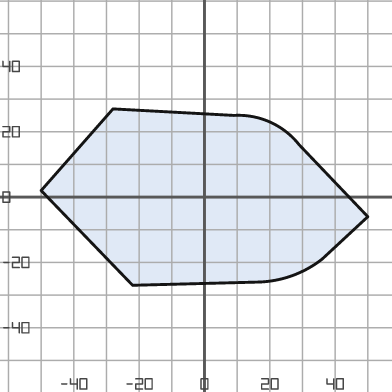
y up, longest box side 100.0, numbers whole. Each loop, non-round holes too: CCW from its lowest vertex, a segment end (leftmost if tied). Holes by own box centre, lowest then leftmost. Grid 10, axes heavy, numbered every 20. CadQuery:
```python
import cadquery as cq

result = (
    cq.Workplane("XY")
    .moveTo(-22.0, -27.0)
    .lineTo(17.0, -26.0)
    .threePointArc((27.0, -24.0), (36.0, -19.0))
    .lineTo(50.0, -6.0)
    .lineTo(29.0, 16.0)
    .threePointArc((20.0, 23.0), (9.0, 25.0))
    .lineTo(-28.0, 27.0)
    .lineTo(-50.0, 2.0)
    .close()
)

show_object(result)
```